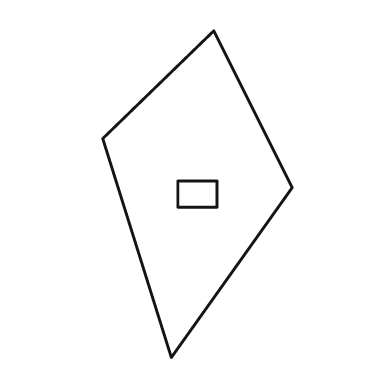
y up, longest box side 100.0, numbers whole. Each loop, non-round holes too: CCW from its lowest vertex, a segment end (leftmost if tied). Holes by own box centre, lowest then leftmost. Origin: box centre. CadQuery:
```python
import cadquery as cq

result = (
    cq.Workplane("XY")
    .moveTo(-8.0, -50.0)
    .lineTo(29.0, 2.0)
    .lineTo(5.0, 50.0)
    .lineTo(-29.0, 17.0)
    .close()
    .moveTo(-6.0, -4.0)
    .lineTo(6.0, -4.0)
    .lineTo(6.0, 4.0)
    .lineTo(-6.0, 4.0)
    .close()
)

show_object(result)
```